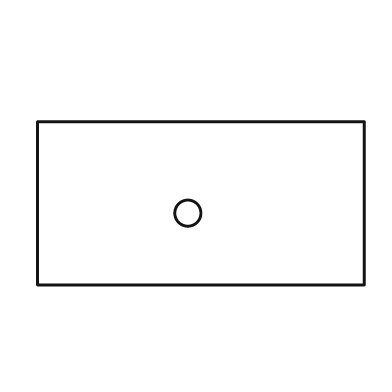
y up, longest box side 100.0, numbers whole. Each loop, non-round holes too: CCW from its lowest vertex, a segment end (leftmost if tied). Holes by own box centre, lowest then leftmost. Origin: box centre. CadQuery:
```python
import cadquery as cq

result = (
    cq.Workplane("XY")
    .moveTo(-50.0, -25.0)
    .lineTo(50.0, -25.0)
    .lineTo(50.0, 25.0)
    .lineTo(-50.0, 25.0)
    .close()
    .moveTo(-4.0, -3.0)
    .circle(4.0)
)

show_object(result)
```